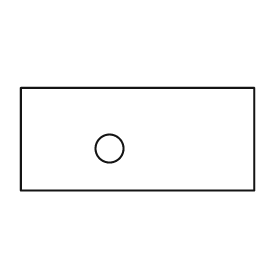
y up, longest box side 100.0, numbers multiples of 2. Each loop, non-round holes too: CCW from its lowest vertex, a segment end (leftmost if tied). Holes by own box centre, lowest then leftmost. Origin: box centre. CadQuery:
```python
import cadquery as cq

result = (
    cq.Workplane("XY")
    .moveTo(-50.0, -22.0)
    .lineTo(50.0, -22.0)
    .lineTo(50.0, 22.0)
    .lineTo(-50.0, 22.0)
    .close()
    .moveTo(-12.0, -4.0)
    .circle(6.0)
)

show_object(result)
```